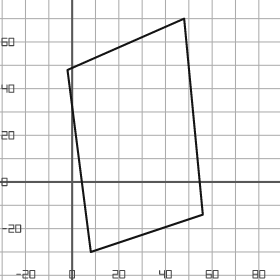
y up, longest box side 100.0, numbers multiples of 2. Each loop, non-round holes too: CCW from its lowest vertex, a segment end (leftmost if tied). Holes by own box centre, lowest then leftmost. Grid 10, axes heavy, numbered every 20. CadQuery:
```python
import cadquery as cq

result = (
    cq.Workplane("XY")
    .moveTo(8.0, -30.0)
    .lineTo(56.0, -14.0)
    .lineTo(48.0, 70.0)
    .lineTo(-2.0, 48.0)
    .close()
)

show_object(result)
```